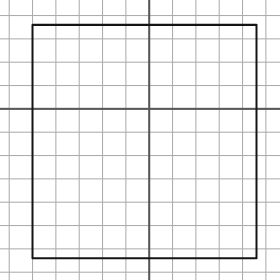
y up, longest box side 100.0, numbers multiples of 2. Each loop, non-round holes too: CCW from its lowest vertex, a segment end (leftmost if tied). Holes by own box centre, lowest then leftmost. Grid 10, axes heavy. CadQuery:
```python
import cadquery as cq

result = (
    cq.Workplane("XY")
    .moveTo(-50.0, -64.0)
    .lineTo(46.0, -64.0)
    .lineTo(46.0, 36.0)
    .lineTo(-50.0, 36.0)
    .close()
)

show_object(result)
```